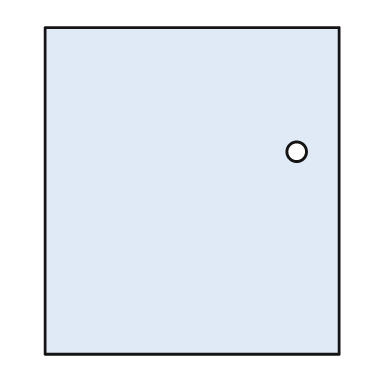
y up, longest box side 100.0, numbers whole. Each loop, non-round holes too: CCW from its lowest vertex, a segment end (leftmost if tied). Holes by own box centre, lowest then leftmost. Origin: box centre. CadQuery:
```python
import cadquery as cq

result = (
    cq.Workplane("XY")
    .moveTo(-45.0, -50.0)
    .lineTo(45.0, -50.0)
    .lineTo(45.0, 50.0)
    .lineTo(-45.0, 50.0)
    .close()
    .moveTo(32.0, 12.0)
    .circle(3.0)
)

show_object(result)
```